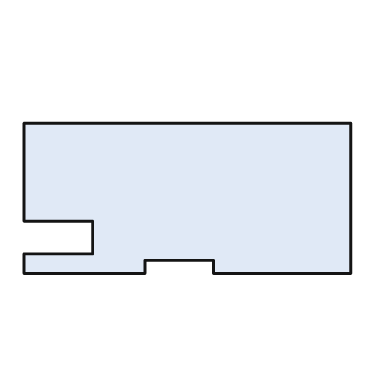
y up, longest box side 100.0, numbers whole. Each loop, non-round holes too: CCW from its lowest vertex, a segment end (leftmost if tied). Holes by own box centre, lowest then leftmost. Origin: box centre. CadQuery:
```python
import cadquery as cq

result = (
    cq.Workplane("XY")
    .moveTo(-50.0, -23.0)
    .lineTo(-13.0, -23.0)
    .lineTo(-13.0, -19.0)
    .lineTo(8.0, -19.0)
    .lineTo(8.0, -23.0)
    .lineTo(50.0, -23.0)
    .lineTo(50.0, 23.0)
    .lineTo(-50.0, 23.0)
    .lineTo(-50.0, -7.0)
    .lineTo(-29.0, -7.0)
    .lineTo(-29.0, -17.0)
    .lineTo(-50.0, -17.0)
    .close()
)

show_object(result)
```